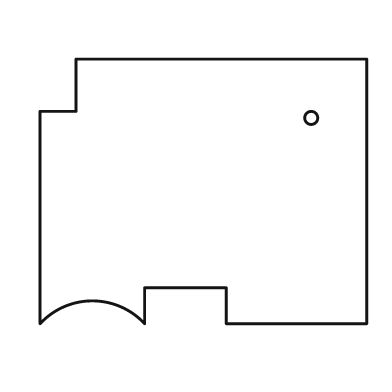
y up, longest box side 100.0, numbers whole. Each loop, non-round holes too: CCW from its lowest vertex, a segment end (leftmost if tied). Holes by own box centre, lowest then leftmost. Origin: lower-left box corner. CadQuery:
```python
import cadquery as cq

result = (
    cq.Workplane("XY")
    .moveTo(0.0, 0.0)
    .threePointArc((16.0, 7.0), (32.0, 0.0))
    .lineTo(32.0, 11.0)
    .lineTo(57.0, 11.0)
    .lineTo(57.0, 0.0)
    .lineTo(100.0, 0.0)
    .lineTo(100.0, 81.0)
    .lineTo(11.0, 81.0)
    .lineTo(11.0, 65.0)
    .lineTo(0.0, 65.0)
    .close()
    .moveTo(83.0, 63.0)
    .circle(2.0)
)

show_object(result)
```